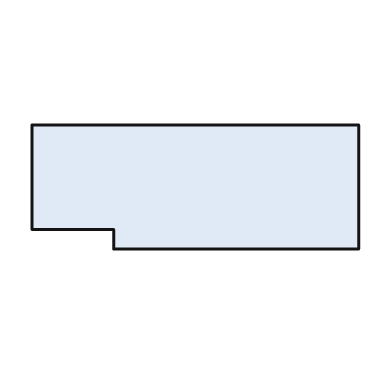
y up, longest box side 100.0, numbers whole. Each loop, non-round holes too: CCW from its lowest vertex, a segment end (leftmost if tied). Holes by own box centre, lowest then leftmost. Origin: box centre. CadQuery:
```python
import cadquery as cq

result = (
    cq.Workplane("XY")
    .moveTo(-25.0, -19.0)
    .lineTo(50.0, -19.0)
    .lineTo(50.0, 19.0)
    .lineTo(-50.0, 19.0)
    .lineTo(-50.0, -13.0)
    .lineTo(-25.0, -13.0)
    .close()
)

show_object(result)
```